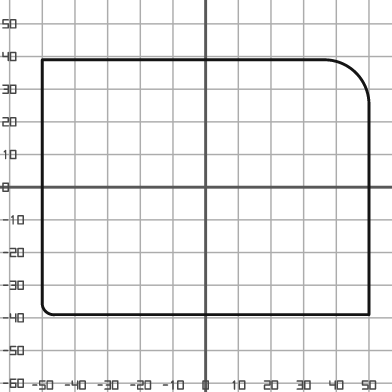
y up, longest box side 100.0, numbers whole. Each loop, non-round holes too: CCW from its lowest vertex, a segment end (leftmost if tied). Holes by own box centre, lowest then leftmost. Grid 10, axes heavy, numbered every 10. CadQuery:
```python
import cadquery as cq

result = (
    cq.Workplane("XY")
    .moveTo(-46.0, -39.0)
    .lineTo(50.0, -39.0)
    .lineTo(50.0, 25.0)
    .threePointArc((46.0, 35.0), (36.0, 39.0))
    .lineTo(-50.0, 39.0)
    .lineTo(-50.0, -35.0)
    .threePointArc((-49.0, -38.0), (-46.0, -39.0))
    .close()
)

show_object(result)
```